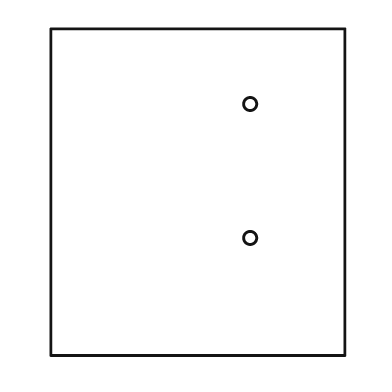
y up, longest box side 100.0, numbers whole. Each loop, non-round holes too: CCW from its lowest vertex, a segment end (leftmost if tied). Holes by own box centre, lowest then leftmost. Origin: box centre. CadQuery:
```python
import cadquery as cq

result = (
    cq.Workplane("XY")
    .moveTo(-45.0, -50.0)
    .lineTo(45.0, -50.0)
    .lineTo(45.0, 50.0)
    .lineTo(-45.0, 50.0)
    .close()
    .moveTo(16.0, -14.0)
    .circle(2.0)
    .moveTo(16.0, 27.0)
    .circle(2.0)
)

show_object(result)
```